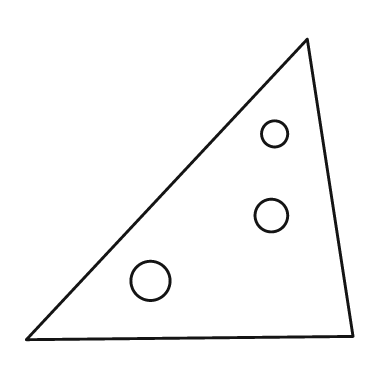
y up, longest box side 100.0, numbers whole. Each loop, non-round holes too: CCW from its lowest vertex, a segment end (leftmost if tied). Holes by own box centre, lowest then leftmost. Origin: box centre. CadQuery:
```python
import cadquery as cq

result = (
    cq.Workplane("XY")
    .moveTo(-50.0, -46.0)
    .lineTo(50.0, -45.0)
    .lineTo(36.0, 46.0)
    .close()
    .moveTo(-12.0, -28.0)
    .circle(6.0)
    .moveTo(25.0, -8.0)
    .circle(5.0)
    .moveTo(26.0, 17.0)
    .circle(4.0)
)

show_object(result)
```